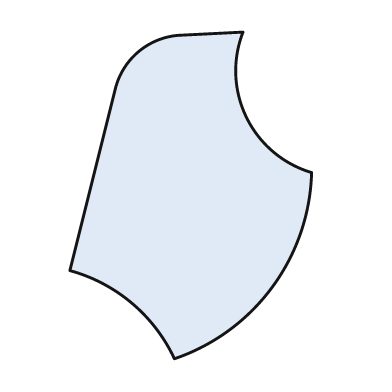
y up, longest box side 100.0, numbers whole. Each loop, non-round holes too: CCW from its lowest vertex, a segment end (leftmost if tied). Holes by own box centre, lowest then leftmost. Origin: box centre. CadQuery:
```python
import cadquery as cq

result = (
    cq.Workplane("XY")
    .moveTo(-5.0, -50.0)
    .threePointArc((25.0, -28.0), (37.0, 7.0))
    .threePointArc((17.0, 24.0), (16.0, 50.0))
    .lineTo(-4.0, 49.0)
    .threePointArc((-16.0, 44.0), (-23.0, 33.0))
    .lineTo(-37.0, -23.0)
    .threePointArc((-18.0, -33.0), (-5.0, -50.0))
    .close()
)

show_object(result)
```